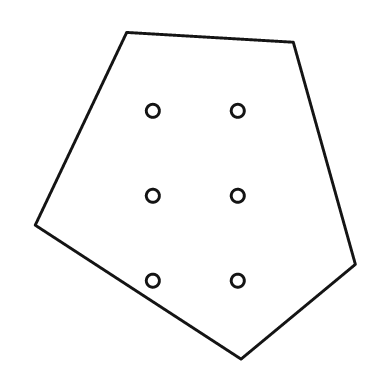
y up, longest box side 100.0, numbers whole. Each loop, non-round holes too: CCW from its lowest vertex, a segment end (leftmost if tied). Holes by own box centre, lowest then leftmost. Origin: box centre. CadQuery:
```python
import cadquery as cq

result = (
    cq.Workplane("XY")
    .moveTo(14.0, -50.0)
    .lineTo(49.0, -21.0)
    .lineTo(30.0, 47.0)
    .lineTo(-21.0, 50.0)
    .lineTo(-49.0, -9.0)
    .close()
    .moveTo(-13.0, -26.0)
    .circle(2.0)
    .moveTo(13.0, -26.0)
    .circle(2.0)
    .moveTo(-13.0, 0.0)
    .circle(2.0)
    .moveTo(13.0, 0.0)
    .circle(2.0)
    .moveTo(-13.0, 26.0)
    .circle(2.0)
    .moveTo(13.0, 26.0)
    .circle(2.0)
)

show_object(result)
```